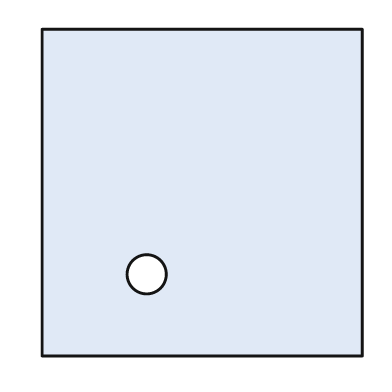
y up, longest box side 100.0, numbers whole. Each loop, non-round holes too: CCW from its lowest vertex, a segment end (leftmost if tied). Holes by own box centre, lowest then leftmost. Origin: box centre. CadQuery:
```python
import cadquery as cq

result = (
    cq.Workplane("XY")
    .moveTo(-49.0, -50.0)
    .lineTo(49.0, -50.0)
    .lineTo(49.0, 50.0)
    .lineTo(-49.0, 50.0)
    .close()
    .moveTo(-17.0, -25.0)
    .circle(6.0)
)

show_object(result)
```